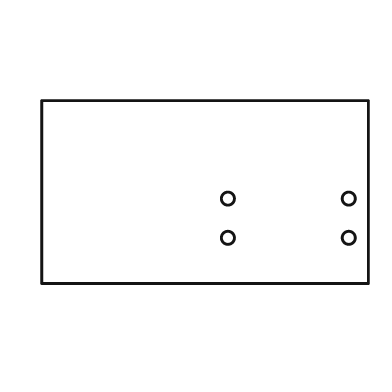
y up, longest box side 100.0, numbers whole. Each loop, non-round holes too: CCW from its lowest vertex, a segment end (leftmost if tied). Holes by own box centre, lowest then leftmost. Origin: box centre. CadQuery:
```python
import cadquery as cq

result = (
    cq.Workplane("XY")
    .moveTo(-50.0, -28.0)
    .lineTo(50.0, -28.0)
    .lineTo(50.0, 28.0)
    .lineTo(-50.0, 28.0)
    .close()
    .moveTo(7.0, -14.0)
    .circle(2.0)
    .moveTo(44.0, -14.0)
    .circle(2.0)
    .moveTo(7.0, -2.0)
    .circle(2.0)
    .moveTo(44.0, -2.0)
    .circle(2.0)
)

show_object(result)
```